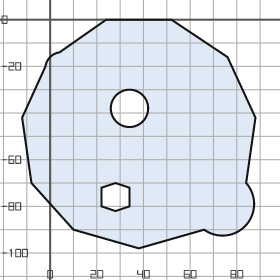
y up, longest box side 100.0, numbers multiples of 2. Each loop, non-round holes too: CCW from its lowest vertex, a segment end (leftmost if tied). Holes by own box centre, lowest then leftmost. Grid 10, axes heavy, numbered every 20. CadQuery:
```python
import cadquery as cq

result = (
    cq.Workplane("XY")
    .moveTo(38.0, -98.0)
    .lineTo(66.0, -90.0)
    .threePointArc((84.0, -88.0), (84.0, -70.0))
    .lineTo(88.0, -42.0)
    .lineTo(76.0, -16.0)
    .lineTo(52.0, 0.0)
    .lineTo(24.0, 0.0)
    .lineTo(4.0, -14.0)
    .threePointArc((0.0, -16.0), (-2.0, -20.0))
    .lineTo(-12.0, -42.0)
    .lineTo(-8.0, -70.0)
    .lineTo(10.0, -90.0)
    .close()
    .moveTo(28.0, -82.0)
    .lineTo(34.0, -80.0)
    .lineTo(34.0, -72.0)
    .lineTo(28.0, -70.0)
    .lineTo(22.0, -72.0)
    .lineTo(22.0, -80.0)
    .close()
    .moveTo(34.0, -38.0)
    .circle(8.0)
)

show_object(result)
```